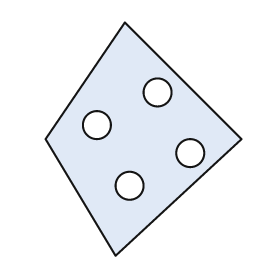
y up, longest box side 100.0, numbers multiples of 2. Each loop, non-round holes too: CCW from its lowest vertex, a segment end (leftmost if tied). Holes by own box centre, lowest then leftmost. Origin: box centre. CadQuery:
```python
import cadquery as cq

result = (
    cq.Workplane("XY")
    .moveTo(-12.0, -50.0)
    .lineTo(42.0, 0.0)
    .lineTo(-8.0, 50.0)
    .lineTo(-42.0, 0.0)
    .close()
    .moveTo(-6.0, -20.0)
    .circle(6.0)
    .moveTo(20.0, -6.0)
    .circle(6.0)
    .moveTo(-20.0, 6.0)
    .circle(6.0)
    .moveTo(6.0, 20.0)
    .circle(6.0)
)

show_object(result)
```